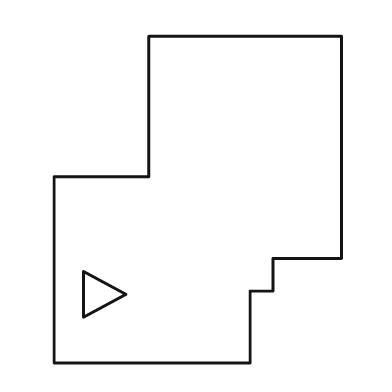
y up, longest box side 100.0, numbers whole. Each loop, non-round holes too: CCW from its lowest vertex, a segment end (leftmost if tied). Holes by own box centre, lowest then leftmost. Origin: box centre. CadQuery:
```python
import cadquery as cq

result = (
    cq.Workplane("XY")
    .moveTo(-44.0, -50.0)
    .lineTo(16.0, -50.0)
    .lineTo(16.0, -28.0)
    .lineTo(23.0, -28.0)
    .lineTo(23.0, -18.0)
    .lineTo(44.0, -18.0)
    .lineTo(44.0, 50.0)
    .lineTo(-15.0, 50.0)
    .lineTo(-15.0, 7.0)
    .lineTo(-44.0, 7.0)
    .close()
    .moveTo(-35.0, -36.0)
    .lineTo(-22.0, -29.0)
    .lineTo(-35.0, -22.0)
    .close()
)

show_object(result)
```